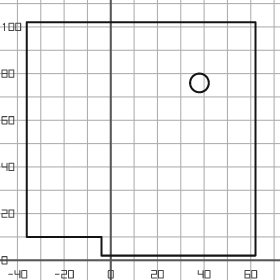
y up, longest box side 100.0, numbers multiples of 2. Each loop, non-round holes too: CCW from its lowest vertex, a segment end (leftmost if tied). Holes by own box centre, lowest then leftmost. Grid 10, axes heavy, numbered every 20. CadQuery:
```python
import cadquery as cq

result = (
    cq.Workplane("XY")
    .moveTo(-4.0, 2.0)
    .lineTo(62.0, 2.0)
    .lineTo(62.0, 102.0)
    .lineTo(-36.0, 102.0)
    .lineTo(-36.0, 10.0)
    .lineTo(-4.0, 10.0)
    .close()
    .moveTo(38.0, 76.0)
    .circle(4.0)
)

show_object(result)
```